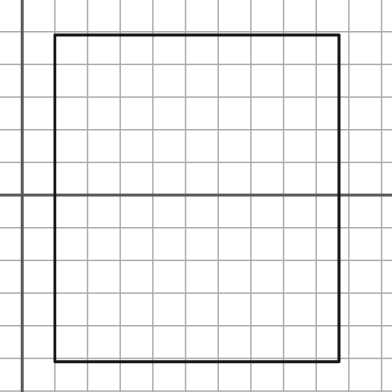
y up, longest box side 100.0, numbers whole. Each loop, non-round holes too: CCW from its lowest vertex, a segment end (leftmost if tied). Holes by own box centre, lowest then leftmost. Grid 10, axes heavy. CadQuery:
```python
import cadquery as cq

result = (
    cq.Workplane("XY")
    .moveTo(10.0, -51.0)
    .lineTo(97.0, -51.0)
    .lineTo(97.0, 49.0)
    .lineTo(10.0, 49.0)
    .close()
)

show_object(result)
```